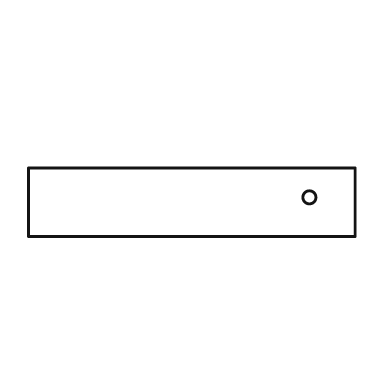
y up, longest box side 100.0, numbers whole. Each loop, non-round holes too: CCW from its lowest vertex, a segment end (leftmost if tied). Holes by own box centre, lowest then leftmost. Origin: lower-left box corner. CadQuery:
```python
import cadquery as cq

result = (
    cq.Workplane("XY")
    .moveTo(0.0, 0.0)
    .lineTo(100.0, 0.0)
    .lineTo(100.0, 21.0)
    .lineTo(0.0, 21.0)
    .close()
    .moveTo(86.0, 12.0)
    .circle(2.0)
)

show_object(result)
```